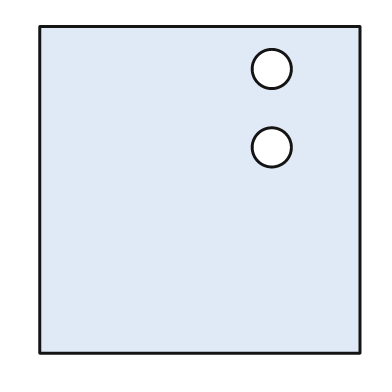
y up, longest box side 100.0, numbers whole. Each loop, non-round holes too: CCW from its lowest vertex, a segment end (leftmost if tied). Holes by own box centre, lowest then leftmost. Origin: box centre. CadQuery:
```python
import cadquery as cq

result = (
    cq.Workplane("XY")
    .moveTo(-49.0, -50.0)
    .lineTo(49.0, -50.0)
    .lineTo(49.0, 50.0)
    .lineTo(-49.0, 50.0)
    .close()
    .moveTo(22.0, 13.0)
    .circle(6.0)
    .moveTo(22.0, 37.0)
    .circle(6.0)
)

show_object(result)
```